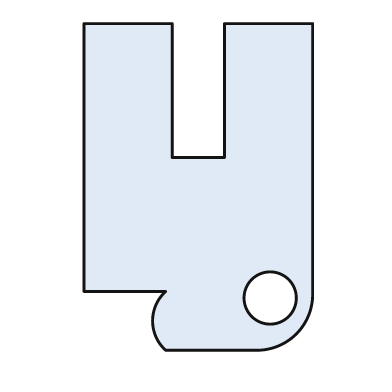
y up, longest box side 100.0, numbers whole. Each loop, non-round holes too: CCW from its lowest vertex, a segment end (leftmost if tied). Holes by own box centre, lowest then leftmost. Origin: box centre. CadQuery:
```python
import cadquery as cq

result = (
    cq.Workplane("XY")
    .moveTo(-10.0, -50.0)
    .lineTo(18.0, -50.0)
    .threePointArc((30.0, -45.0), (35.0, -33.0))
    .lineTo(35.0, 50.0)
    .lineTo(8.0, 50.0)
    .lineTo(8.0, 9.0)
    .lineTo(-8.0, 9.0)
    .lineTo(-8.0, 50.0)
    .lineTo(-35.0, 50.0)
    .lineTo(-35.0, -32.0)
    .lineTo(-10.0, -32.0)
    .threePointArc((-14.0, -41.0), (-10.0, -50.0))
    .close()
    .moveTo(22.0, -34.0)
    .circle(8.0)
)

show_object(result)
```